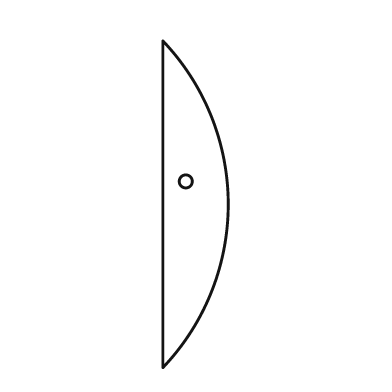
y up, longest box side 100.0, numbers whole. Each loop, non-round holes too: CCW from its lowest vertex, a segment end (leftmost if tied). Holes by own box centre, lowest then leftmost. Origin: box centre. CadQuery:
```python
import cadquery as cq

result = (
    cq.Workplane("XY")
    .moveTo(-10.0, -50.0)
    .threePointArc((10.0, 0.0), (-10.0, 50.0))
    .close()
    .moveTo(-3.0, 7.0)
    .circle(2.0)
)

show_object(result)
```